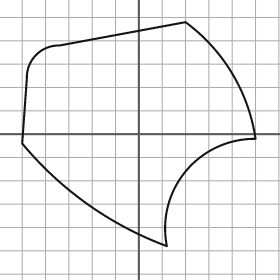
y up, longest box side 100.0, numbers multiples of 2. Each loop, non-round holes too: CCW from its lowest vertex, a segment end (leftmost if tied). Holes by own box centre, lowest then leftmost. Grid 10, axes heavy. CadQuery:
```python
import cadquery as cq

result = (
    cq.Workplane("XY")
    .moveTo(12.0, -48.0)
    .threePointArc((20.0, -16.0), (50.0, -2.0))
    .threePointArc((40.0, 26.0), (20.0, 48.0))
    .lineTo(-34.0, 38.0)
    .threePointArc((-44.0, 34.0), (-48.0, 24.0))
    .lineTo(-50.0, -4.0)
    .threePointArc((-22.0, -30.0), (12.0, -48.0))
    .close()
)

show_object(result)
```